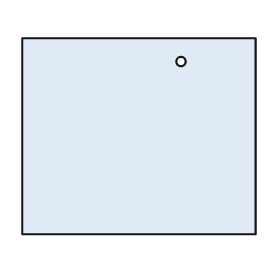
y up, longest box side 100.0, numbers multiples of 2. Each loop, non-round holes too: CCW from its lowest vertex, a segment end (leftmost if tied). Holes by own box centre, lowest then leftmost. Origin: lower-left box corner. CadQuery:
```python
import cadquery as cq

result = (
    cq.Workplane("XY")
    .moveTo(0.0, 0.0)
    .lineTo(100.0, 0.0)
    .lineTo(100.0, 84.0)
    .lineTo(0.0, 84.0)
    .close()
    .moveTo(68.0, 74.0)
    .circle(2.0)
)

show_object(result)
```